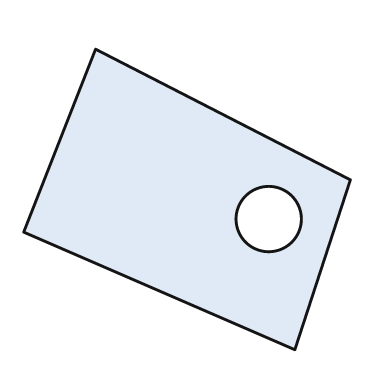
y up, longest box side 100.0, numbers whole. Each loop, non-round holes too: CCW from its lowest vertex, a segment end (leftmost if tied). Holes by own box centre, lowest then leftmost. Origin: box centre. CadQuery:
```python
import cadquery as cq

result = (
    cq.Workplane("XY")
    .moveTo(33.0, -46.0)
    .lineTo(50.0, 6.0)
    .lineTo(-28.0, 46.0)
    .lineTo(-50.0, -10.0)
    .close()
    .moveTo(25.0, -6.0)
    .circle(10.0)
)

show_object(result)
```